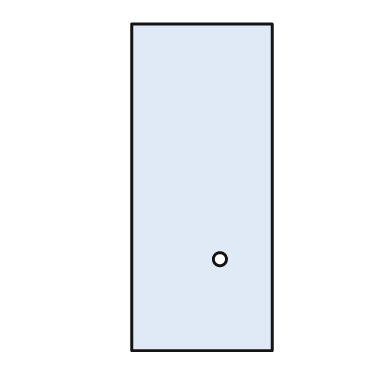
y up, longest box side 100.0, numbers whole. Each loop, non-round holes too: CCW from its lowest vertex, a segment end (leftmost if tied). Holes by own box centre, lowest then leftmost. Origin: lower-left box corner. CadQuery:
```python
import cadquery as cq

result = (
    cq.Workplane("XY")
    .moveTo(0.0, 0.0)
    .lineTo(43.0, 0.0)
    .lineTo(43.0, 100.0)
    .lineTo(0.0, 100.0)
    .close()
    .moveTo(27.0, 28.0)
    .circle(2.0)
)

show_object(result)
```